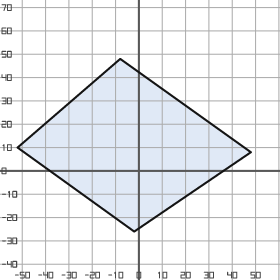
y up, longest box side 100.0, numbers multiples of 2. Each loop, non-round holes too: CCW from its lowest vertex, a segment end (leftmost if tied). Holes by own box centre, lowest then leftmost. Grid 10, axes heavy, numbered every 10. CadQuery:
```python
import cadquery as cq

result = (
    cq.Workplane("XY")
    .moveTo(-2.0, -26.0)
    .lineTo(48.0, 8.0)
    .lineTo(-8.0, 48.0)
    .lineTo(-52.0, 10.0)
    .close()
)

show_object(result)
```